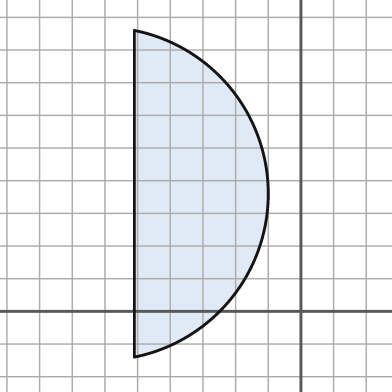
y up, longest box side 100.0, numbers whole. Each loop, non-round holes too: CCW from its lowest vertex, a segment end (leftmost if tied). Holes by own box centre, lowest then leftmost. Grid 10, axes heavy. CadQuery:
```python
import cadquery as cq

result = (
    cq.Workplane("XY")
    .moveTo(-51.0, -14.0)
    .threePointArc((-10.0, 36.0), (-51.0, 86.0))
    .close()
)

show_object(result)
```